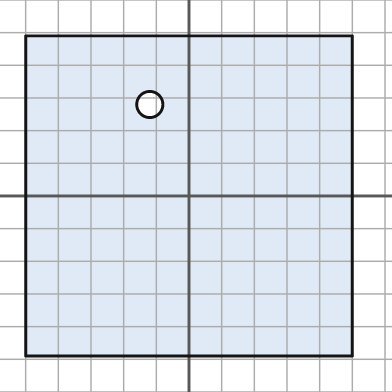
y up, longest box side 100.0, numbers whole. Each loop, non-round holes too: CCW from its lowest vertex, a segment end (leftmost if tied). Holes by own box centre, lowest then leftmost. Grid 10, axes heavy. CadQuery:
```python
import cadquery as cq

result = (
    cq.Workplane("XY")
    .moveTo(-50.0, -49.0)
    .lineTo(50.0, -49.0)
    .lineTo(50.0, 49.0)
    .lineTo(-50.0, 49.0)
    .close()
    .moveTo(-12.0, 28.0)
    .circle(4.0)
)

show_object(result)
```